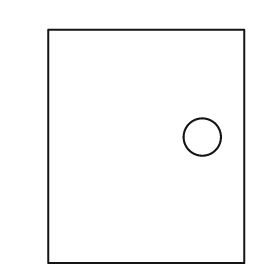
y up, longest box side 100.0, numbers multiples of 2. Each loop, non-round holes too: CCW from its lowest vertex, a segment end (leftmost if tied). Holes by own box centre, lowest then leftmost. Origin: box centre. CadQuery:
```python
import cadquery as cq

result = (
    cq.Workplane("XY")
    .moveTo(-42.0, -50.0)
    .lineTo(42.0, -50.0)
    .lineTo(42.0, 50.0)
    .lineTo(-42.0, 50.0)
    .close()
    .moveTo(24.0, 4.0)
    .circle(8.0)
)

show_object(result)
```